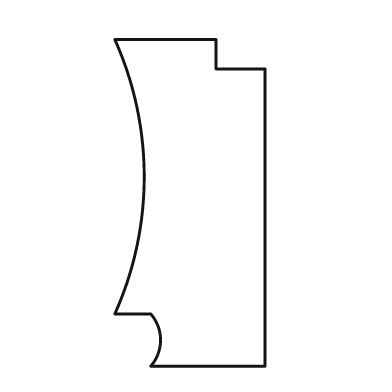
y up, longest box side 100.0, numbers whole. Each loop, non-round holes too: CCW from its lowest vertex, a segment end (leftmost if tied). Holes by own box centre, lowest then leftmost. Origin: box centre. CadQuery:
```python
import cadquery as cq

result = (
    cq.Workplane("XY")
    .moveTo(-12.0, -50.0)
    .lineTo(23.0, -50.0)
    .lineTo(23.0, 41.0)
    .lineTo(8.0, 41.0)
    .lineTo(8.0, 50.0)
    .lineTo(-23.0, 50.0)
    .threePointArc((-14.0, 8.0), (-23.0, -34.0))
    .lineTo(-12.0, -34.0)
    .threePointArc((-9.0, -42.0), (-12.0, -50.0))
    .close()
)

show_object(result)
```